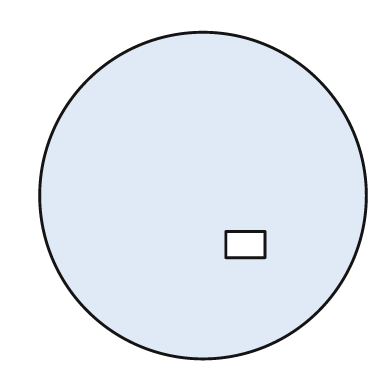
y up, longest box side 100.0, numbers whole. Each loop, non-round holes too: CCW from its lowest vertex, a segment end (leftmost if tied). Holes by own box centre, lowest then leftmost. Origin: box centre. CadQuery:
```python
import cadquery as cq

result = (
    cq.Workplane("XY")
    .moveTo(0.0, 0.0)
    .circle(50.0)
    .moveTo(7.0, -19.0)
    .lineTo(19.0, -19.0)
    .lineTo(19.0, -11.0)
    .lineTo(7.0, -11.0)
    .close()
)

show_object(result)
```